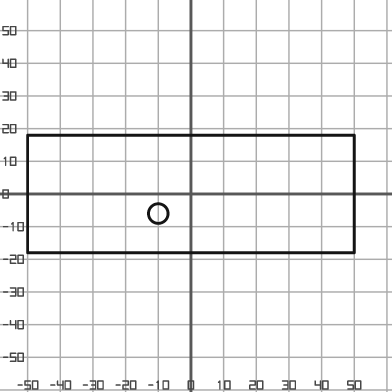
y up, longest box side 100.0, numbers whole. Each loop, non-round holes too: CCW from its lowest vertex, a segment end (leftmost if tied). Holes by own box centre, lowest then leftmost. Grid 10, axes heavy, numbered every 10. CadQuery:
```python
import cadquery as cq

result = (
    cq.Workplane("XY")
    .moveTo(-50.0, -18.0)
    .lineTo(50.0, -18.0)
    .lineTo(50.0, 18.0)
    .lineTo(-50.0, 18.0)
    .close()
    .moveTo(-10.0, -6.0)
    .circle(3.0)
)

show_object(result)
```